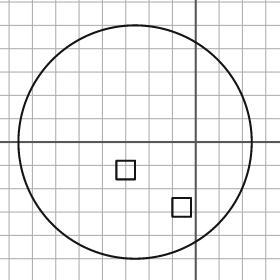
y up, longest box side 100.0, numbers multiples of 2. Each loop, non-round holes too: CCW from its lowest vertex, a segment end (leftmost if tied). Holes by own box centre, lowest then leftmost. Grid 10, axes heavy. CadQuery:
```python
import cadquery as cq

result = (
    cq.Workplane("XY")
    .moveTo(-26.0, 0.0)
    .circle(50.0)
    .moveTo(-10.0, -32.0)
    .lineTo(-2.0, -32.0)
    .lineTo(-2.0, -24.0)
    .lineTo(-10.0, -24.0)
    .close()
    .moveTo(-34.0, -16.0)
    .lineTo(-26.0, -16.0)
    .lineTo(-26.0, -8.0)
    .lineTo(-34.0, -8.0)
    .close()
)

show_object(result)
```